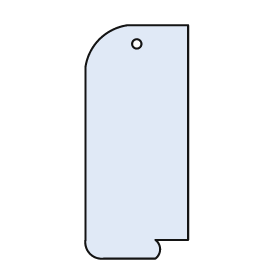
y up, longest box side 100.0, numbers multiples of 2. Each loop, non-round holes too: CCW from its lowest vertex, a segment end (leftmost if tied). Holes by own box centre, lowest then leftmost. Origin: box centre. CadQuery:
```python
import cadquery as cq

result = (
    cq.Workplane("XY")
    .moveTo(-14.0, -50.0)
    .lineTo(8.0, -50.0)
    .threePointArc((10.0, -46.0), (8.0, -42.0))
    .lineTo(22.0, -42.0)
    .lineTo(22.0, 50.0)
    .lineTo(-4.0, 50.0)
    .threePointArc((-16.0, 44.0), (-22.0, 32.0))
    .lineTo(-22.0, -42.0)
    .threePointArc((-20.0, -48.0), (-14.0, -50.0))
    .close()
    .moveTo(0.0, 42.0)
    .circle(2.0)
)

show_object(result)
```